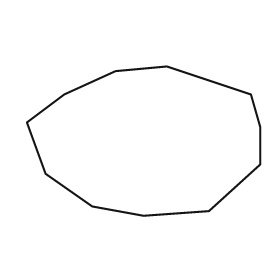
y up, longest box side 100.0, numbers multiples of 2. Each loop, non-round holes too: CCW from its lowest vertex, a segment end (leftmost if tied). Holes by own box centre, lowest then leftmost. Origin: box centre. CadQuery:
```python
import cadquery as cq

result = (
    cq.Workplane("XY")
    .moveTo(0.0, -32.0)
    .lineTo(28.0, -30.0)
    .lineTo(50.0, -10.0)
    .lineTo(50.0, 6.0)
    .lineTo(46.0, 20.0)
    .lineTo(10.0, 32.0)
    .lineTo(-12.0, 30.0)
    .lineTo(-34.0, 20.0)
    .lineTo(-50.0, 8.0)
    .lineTo(-42.0, -14.0)
    .lineTo(-22.0, -28.0)
    .close()
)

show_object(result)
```